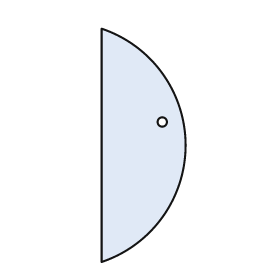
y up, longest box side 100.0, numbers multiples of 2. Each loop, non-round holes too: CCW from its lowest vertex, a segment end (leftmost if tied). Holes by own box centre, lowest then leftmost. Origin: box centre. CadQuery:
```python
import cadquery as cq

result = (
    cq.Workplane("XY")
    .moveTo(-18.0, -50.0)
    .threePointArc((18.0, 0.0), (-18.0, 50.0))
    .close()
    .moveTo(8.0, 10.0)
    .circle(2.0)
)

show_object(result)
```